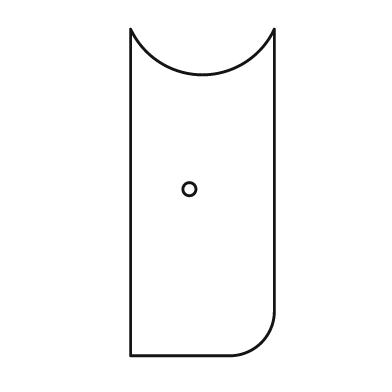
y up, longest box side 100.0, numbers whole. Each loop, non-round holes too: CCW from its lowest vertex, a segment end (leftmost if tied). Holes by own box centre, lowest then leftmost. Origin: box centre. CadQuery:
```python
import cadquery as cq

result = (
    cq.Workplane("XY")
    .moveTo(-22.0, -50.0)
    .lineTo(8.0, -50.0)
    .threePointArc((18.0, -46.0), (22.0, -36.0))
    .lineTo(22.0, 50.0)
    .threePointArc((0.0, 36.0), (-22.0, 50.0))
    .close()
    .moveTo(-4.0, 1.0)
    .circle(2.0)
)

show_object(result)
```